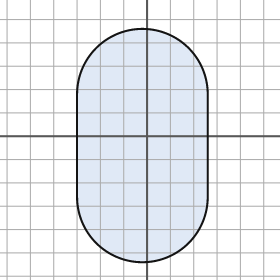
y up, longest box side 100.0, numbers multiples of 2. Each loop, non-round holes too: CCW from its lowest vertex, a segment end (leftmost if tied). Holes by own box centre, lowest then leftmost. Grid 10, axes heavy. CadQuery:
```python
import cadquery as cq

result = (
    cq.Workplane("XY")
    .moveTo(-30.0, -26.0)
    .threePointArc((-2.0, -54.0), (26.0, -26.0))
    .lineTo(26.0, 18.0)
    .threePointArc((-2.0, 46.0), (-30.0, 18.0))
    .close()
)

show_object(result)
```